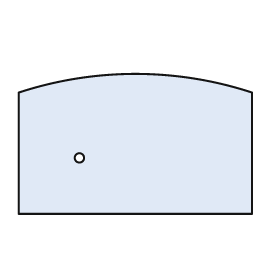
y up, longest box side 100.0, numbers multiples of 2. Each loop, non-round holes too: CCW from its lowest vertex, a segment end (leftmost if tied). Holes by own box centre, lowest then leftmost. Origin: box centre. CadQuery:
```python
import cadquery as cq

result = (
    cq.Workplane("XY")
    .moveTo(-50.0, -30.0)
    .lineTo(50.0, -30.0)
    .lineTo(50.0, 22.0)
    .threePointArc((0.0, 30.0), (-50.0, 22.0))
    .close()
    .moveTo(-24.0, -6.0)
    .circle(2.0)
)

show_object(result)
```